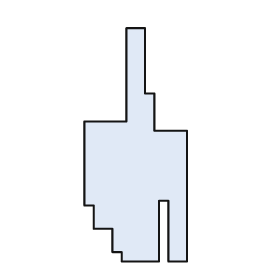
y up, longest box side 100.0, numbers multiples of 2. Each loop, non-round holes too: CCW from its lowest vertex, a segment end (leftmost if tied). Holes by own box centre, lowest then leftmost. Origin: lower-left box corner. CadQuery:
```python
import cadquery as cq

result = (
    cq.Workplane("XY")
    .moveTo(16.0, 0.0)
    .lineTo(32.0, 0.0)
    .lineTo(32.0, 26.0)
    .lineTo(36.0, 26.0)
    .lineTo(36.0, 0.0)
    .lineTo(44.0, 0.0)
    .lineTo(44.0, 56.0)
    .lineTo(30.0, 56.0)
    .lineTo(30.0, 72.0)
    .lineTo(26.0, 72.0)
    .lineTo(26.0, 100.0)
    .lineTo(18.0, 100.0)
    .lineTo(18.0, 60.0)
    .lineTo(0.0, 60.0)
    .lineTo(0.0, 24.0)
    .lineTo(4.0, 24.0)
    .lineTo(4.0, 14.0)
    .lineTo(12.0, 14.0)
    .lineTo(12.0, 4.0)
    .lineTo(16.0, 4.0)
    .close()
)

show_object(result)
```